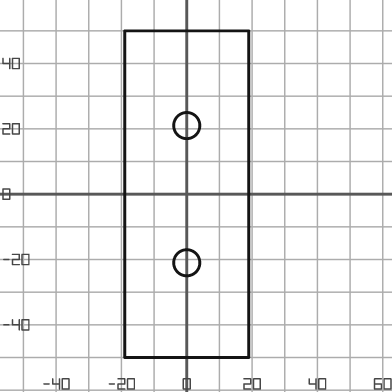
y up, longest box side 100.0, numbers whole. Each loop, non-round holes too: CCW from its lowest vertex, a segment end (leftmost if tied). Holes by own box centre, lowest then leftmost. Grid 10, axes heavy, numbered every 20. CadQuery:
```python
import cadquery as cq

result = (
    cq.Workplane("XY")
    .moveTo(-19.0, -50.0)
    .lineTo(19.0, -50.0)
    .lineTo(19.0, 50.0)
    .lineTo(-19.0, 50.0)
    .close()
    .moveTo(0.0, -21.0)
    .circle(4.0)
    .moveTo(0.0, 21.0)
    .circle(4.0)
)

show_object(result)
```